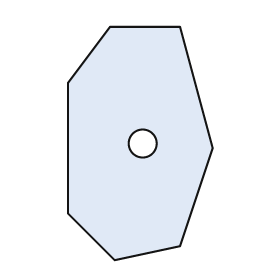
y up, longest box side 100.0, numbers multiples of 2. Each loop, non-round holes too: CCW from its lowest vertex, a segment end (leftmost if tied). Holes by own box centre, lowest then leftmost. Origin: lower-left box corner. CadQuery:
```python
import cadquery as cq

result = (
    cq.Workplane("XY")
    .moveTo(20.0, 0.0)
    .lineTo(48.0, 6.0)
    .lineTo(62.0, 48.0)
    .lineTo(48.0, 100.0)
    .lineTo(18.0, 100.0)
    .lineTo(0.0, 76.0)
    .lineTo(0.0, 20.0)
    .close()
    .moveTo(32.0, 50.0)
    .circle(6.0)
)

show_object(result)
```